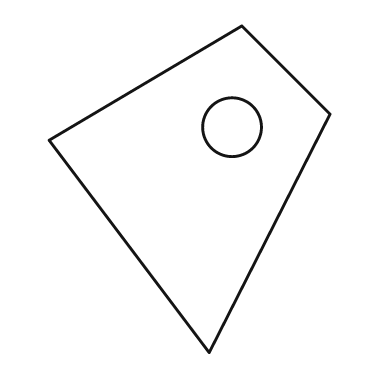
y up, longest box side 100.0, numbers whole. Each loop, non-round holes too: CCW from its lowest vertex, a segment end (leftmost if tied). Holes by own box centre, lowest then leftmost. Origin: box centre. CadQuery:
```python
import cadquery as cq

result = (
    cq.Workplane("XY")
    .moveTo(6.0, -50.0)
    .lineTo(43.0, 23.0)
    .lineTo(16.0, 50.0)
    .lineTo(-43.0, 15.0)
    .close()
    .moveTo(13.0, 19.0)
    .circle(9.0)
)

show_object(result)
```